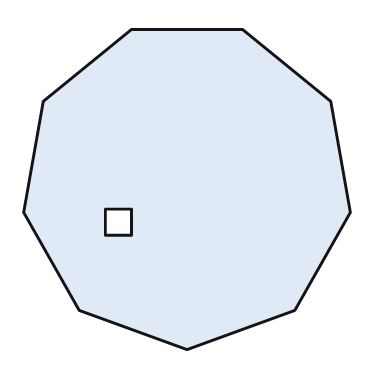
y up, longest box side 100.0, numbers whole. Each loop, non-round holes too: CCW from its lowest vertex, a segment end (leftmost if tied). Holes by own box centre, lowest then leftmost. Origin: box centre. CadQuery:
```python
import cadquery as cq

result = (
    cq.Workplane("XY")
    .moveTo(0.0, -49.0)
    .lineTo(33.0, -37.0)
    .lineTo(50.0, -7.0)
    .lineTo(44.0, 27.0)
    .lineTo(17.0, 49.0)
    .lineTo(-17.0, 49.0)
    .lineTo(-44.0, 27.0)
    .lineTo(-50.0, -7.0)
    .lineTo(-33.0, -37.0)
    .close()
    .moveTo(-25.0, -14.0)
    .lineTo(-17.0, -14.0)
    .lineTo(-17.0, -6.0)
    .lineTo(-25.0, -6.0)
    .close()
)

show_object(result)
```